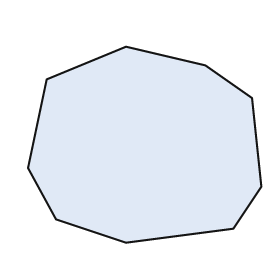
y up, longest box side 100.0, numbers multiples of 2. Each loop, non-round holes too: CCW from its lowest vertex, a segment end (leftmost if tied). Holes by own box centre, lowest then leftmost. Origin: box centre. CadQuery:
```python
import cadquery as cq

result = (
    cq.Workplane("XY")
    .moveTo(-8.0, -42.0)
    .lineTo(38.0, -36.0)
    .lineTo(50.0, -18.0)
    .lineTo(46.0, 20.0)
    .lineTo(26.0, 34.0)
    .lineTo(-8.0, 42.0)
    .lineTo(-42.0, 28.0)
    .lineTo(-50.0, -10.0)
    .lineTo(-38.0, -32.0)
    .close()
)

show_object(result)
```